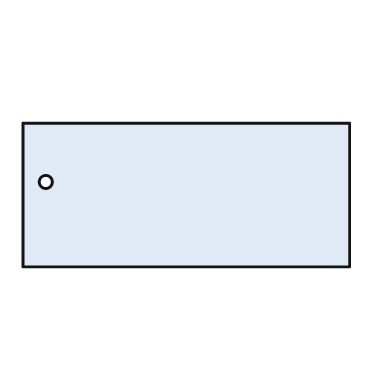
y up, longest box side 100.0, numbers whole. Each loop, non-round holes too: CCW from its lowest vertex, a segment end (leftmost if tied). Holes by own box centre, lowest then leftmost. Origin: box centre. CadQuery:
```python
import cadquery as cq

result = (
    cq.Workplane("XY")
    .moveTo(-50.0, -22.0)
    .lineTo(50.0, -22.0)
    .lineTo(50.0, 22.0)
    .lineTo(-50.0, 22.0)
    .close()
    .moveTo(-43.0, 4.0)
    .circle(2.0)
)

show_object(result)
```